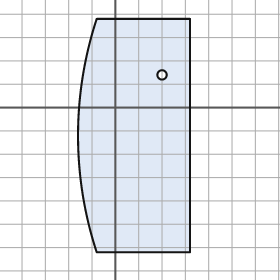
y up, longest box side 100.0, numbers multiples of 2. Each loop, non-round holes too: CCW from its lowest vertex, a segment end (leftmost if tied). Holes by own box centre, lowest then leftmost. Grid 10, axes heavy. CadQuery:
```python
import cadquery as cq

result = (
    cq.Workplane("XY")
    .moveTo(-8.0, -62.0)
    .lineTo(32.0, -62.0)
    .lineTo(32.0, 38.0)
    .lineTo(-8.0, 38.0)
    .threePointArc((-16.0, -12.0), (-8.0, -62.0))
    .close()
    .moveTo(20.0, 14.0)
    .circle(2.0)
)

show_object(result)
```